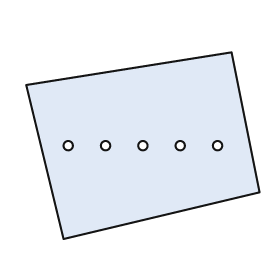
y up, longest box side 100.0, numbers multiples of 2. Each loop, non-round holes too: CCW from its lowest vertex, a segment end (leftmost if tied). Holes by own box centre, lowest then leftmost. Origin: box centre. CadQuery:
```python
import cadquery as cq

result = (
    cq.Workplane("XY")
    .moveTo(-34.0, -40.0)
    .lineTo(50.0, -20.0)
    .lineTo(38.0, 40.0)
    .lineTo(-50.0, 26.0)
    .close()
    .moveTo(-32.0, 0.0)
    .circle(2.0)
    .moveTo(-16.0, 0.0)
    .circle(2.0)
    .moveTo(0.0, 0.0)
    .circle(2.0)
    .moveTo(16.0, 0.0)
    .circle(2.0)
    .moveTo(32.0, 0.0)
    .circle(2.0)
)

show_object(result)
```